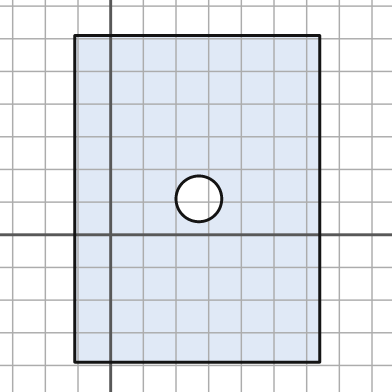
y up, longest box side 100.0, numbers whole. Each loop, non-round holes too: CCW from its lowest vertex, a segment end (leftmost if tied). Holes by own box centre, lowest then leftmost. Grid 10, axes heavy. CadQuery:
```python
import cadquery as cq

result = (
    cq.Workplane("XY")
    .moveTo(-11.0, -39.0)
    .lineTo(64.0, -39.0)
    .lineTo(64.0, 61.0)
    .lineTo(-11.0, 61.0)
    .close()
    .moveTo(27.0, 11.0)
    .circle(7.0)
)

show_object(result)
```